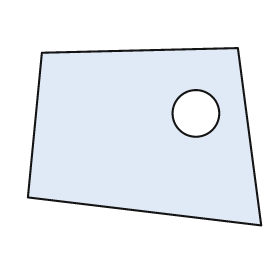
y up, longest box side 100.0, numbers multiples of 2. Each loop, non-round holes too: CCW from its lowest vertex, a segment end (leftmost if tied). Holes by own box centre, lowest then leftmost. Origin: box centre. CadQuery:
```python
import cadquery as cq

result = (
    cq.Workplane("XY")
    .moveTo(50.0, -38.0)
    .lineTo(40.0, 38.0)
    .lineTo(-44.0, 36.0)
    .lineTo(-50.0, -26.0)
    .close()
    .moveTo(22.0, 10.0)
    .circle(10.0)
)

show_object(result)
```